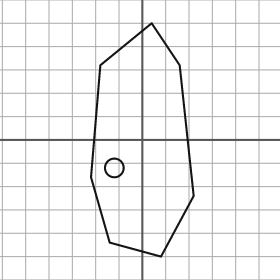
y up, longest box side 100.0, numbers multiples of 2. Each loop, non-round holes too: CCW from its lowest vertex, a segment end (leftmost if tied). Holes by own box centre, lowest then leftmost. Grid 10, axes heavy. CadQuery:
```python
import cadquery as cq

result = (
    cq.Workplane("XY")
    .moveTo(8.0, -50.0)
    .lineTo(22.0, -24.0)
    .lineTo(16.0, 32.0)
    .lineTo(4.0, 50.0)
    .lineTo(-18.0, 32.0)
    .lineTo(-22.0, -16.0)
    .lineTo(-14.0, -44.0)
    .close()
    .moveTo(-12.0, -12.0)
    .circle(4.0)
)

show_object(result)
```